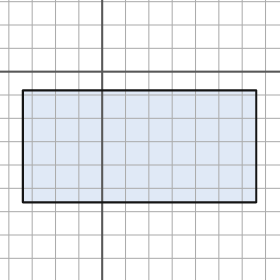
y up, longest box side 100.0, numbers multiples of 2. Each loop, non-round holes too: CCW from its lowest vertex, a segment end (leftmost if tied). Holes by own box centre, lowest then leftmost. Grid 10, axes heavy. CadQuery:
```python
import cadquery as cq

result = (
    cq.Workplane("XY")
    .moveTo(-34.0, -56.0)
    .lineTo(66.0, -56.0)
    .lineTo(66.0, -8.0)
    .lineTo(-34.0, -8.0)
    .close()
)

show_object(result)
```